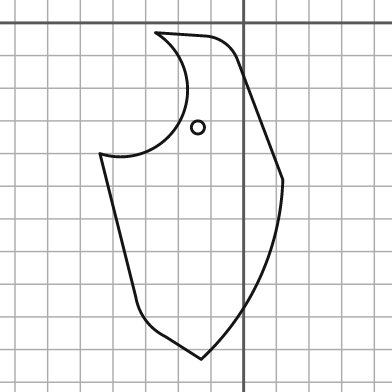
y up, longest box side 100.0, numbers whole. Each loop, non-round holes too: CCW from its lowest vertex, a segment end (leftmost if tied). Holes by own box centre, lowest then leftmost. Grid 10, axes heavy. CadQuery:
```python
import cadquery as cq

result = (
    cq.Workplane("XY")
    .moveTo(-13.0, -103.0)
    .threePointArc((5.0, -78.0), (12.0, -48.0))
    .lineTo(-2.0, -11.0)
    .threePointArc((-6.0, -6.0), (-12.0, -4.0))
    .lineTo(-27.0, -3.0)
    .threePointArc((-19.0, -29.0), (-44.0, -40.0))
    .lineTo(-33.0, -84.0)
    .threePointArc((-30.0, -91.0), (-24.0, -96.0))
    .close()
    .moveTo(-14.0, -32.0)
    .circle(2.0)
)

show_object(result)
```